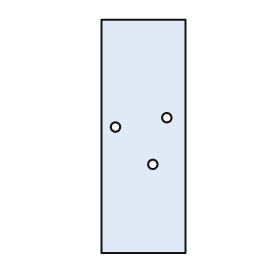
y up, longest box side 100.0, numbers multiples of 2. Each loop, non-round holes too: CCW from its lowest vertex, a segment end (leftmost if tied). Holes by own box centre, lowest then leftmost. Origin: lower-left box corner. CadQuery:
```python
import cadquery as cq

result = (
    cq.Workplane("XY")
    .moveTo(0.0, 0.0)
    .lineTo(36.0, 0.0)
    .lineTo(36.0, 100.0)
    .lineTo(0.0, 100.0)
    .close()
    .moveTo(22.0, 38.0)
    .circle(2.0)
    .moveTo(6.0, 54.0)
    .circle(2.0)
    .moveTo(28.0, 58.0)
    .circle(2.0)
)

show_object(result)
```